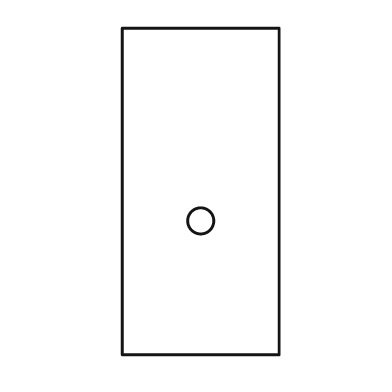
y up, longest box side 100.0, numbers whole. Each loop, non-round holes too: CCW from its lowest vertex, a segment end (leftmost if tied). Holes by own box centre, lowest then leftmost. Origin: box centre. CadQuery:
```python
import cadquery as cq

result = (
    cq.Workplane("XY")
    .moveTo(-24.0, -50.0)
    .lineTo(24.0, -50.0)
    .lineTo(24.0, 50.0)
    .lineTo(-24.0, 50.0)
    .close()
    .moveTo(0.0, -9.0)
    .circle(4.0)
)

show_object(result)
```